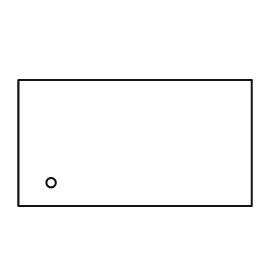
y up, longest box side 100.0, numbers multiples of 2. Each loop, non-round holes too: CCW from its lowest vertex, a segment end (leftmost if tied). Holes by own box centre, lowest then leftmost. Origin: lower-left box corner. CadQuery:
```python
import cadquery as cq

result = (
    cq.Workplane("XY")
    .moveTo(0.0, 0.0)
    .lineTo(100.0, 0.0)
    .lineTo(100.0, 54.0)
    .lineTo(0.0, 54.0)
    .close()
    .moveTo(14.0, 10.0)
    .circle(2.0)
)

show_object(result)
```